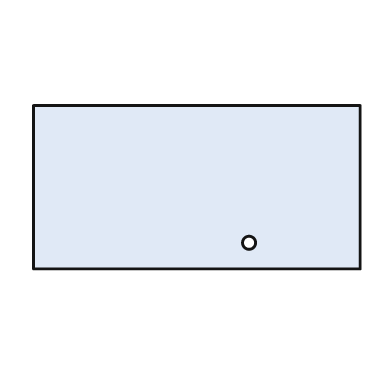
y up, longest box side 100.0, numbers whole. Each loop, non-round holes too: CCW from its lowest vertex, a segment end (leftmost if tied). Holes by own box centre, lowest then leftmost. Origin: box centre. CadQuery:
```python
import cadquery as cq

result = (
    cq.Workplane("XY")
    .moveTo(-50.0, -25.0)
    .lineTo(50.0, -25.0)
    .lineTo(50.0, 25.0)
    .lineTo(-50.0, 25.0)
    .close()
    .moveTo(16.0, -17.0)
    .circle(2.0)
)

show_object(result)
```